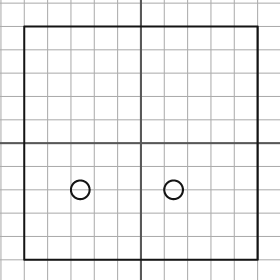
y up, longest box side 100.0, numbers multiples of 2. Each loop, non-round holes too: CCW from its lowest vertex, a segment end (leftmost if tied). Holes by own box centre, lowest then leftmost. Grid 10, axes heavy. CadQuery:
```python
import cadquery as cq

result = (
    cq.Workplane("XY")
    .moveTo(-50.0, -50.0)
    .lineTo(50.0, -50.0)
    .lineTo(50.0, 50.0)
    .lineTo(-50.0, 50.0)
    .close()
    .moveTo(-26.0, -20.0)
    .circle(4.0)
    .moveTo(14.0, -20.0)
    .circle(4.0)
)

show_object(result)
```